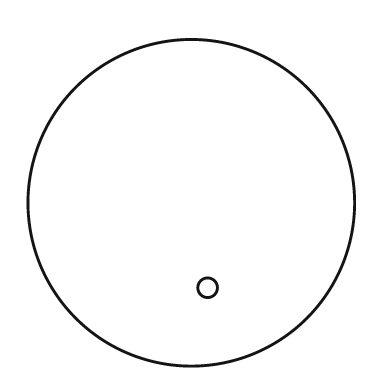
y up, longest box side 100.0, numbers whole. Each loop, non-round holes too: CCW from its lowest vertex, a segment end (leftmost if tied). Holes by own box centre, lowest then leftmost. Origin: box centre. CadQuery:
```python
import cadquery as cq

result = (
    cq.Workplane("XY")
    .moveTo(0.0, 0.0)
    .circle(50.0)
    .moveTo(5.0, -26.0)
    .circle(3.0)
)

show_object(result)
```